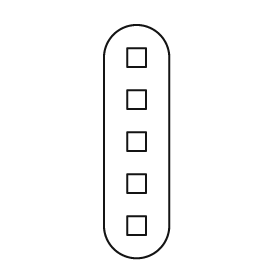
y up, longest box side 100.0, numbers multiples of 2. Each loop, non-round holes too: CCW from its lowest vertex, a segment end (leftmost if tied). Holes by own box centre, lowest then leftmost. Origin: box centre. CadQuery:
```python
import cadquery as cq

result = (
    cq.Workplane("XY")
    .moveTo(-14.0, -36.0)
    .threePointArc((0.0, -50.0), (14.0, -36.0))
    .lineTo(14.0, 36.0)
    .threePointArc((0.0, 50.0), (-14.0, 36.0))
    .close()
    .moveTo(-4.0, -40.0)
    .lineTo(4.0, -40.0)
    .lineTo(4.0, -32.0)
    .lineTo(-4.0, -32.0)
    .close()
    .moveTo(-4.0, -22.0)
    .lineTo(4.0, -22.0)
    .lineTo(4.0, -14.0)
    .lineTo(-4.0, -14.0)
    .close()
    .moveTo(-4.0, -4.0)
    .lineTo(4.0, -4.0)
    .lineTo(4.0, 4.0)
    .lineTo(-4.0, 4.0)
    .close()
    .moveTo(-4.0, 14.0)
    .lineTo(4.0, 14.0)
    .lineTo(4.0, 22.0)
    .lineTo(-4.0, 22.0)
    .close()
    .moveTo(-4.0, 32.0)
    .lineTo(4.0, 32.0)
    .lineTo(4.0, 40.0)
    .lineTo(-4.0, 40.0)
    .close()
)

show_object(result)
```